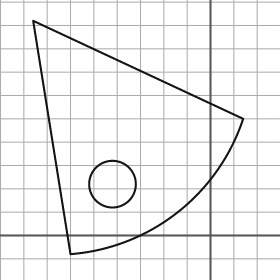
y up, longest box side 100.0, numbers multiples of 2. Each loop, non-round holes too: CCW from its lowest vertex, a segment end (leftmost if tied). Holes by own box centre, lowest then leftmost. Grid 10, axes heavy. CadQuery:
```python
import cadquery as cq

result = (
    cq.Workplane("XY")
    .moveTo(-60.0, -8.0)
    .threePointArc((-14.0, 10.0), (14.0, 50.0))
    .lineTo(-76.0, 92.0)
    .close()
    .moveTo(-42.0, 22.0)
    .circle(10.0)
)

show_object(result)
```